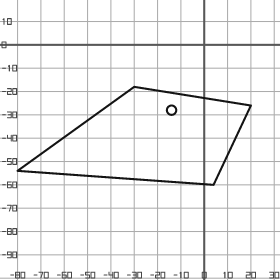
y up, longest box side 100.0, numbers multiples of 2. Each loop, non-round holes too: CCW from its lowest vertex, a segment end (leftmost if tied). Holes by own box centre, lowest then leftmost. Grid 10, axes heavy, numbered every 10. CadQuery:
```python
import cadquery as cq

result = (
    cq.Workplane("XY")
    .moveTo(4.0, -60.0)
    .lineTo(20.0, -26.0)
    .lineTo(-30.0, -18.0)
    .lineTo(-80.0, -54.0)
    .close()
    .moveTo(-14.0, -28.0)
    .circle(2.0)
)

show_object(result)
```